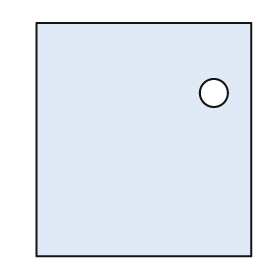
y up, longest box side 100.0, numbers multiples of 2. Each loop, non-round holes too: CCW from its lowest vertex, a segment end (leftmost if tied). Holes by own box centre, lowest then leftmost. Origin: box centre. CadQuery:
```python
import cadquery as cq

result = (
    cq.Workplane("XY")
    .moveTo(-46.0, -50.0)
    .lineTo(46.0, -50.0)
    .lineTo(46.0, 50.0)
    .lineTo(-46.0, 50.0)
    .close()
    .moveTo(30.0, 20.0)
    .circle(6.0)
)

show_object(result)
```